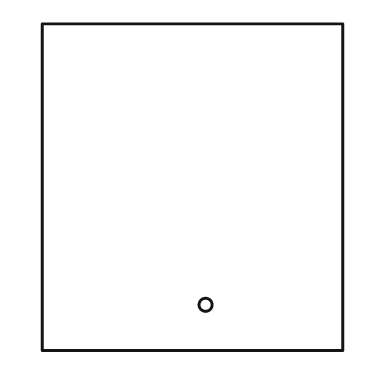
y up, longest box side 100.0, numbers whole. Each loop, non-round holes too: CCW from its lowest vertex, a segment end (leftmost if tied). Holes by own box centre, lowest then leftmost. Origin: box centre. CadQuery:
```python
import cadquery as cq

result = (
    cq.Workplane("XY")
    .moveTo(-46.0, -50.0)
    .lineTo(46.0, -50.0)
    .lineTo(46.0, 50.0)
    .lineTo(-46.0, 50.0)
    .close()
    .moveTo(4.0, -36.0)
    .circle(2.0)
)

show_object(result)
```